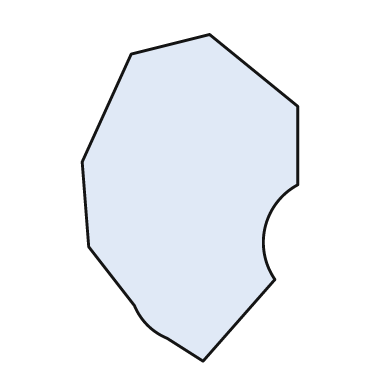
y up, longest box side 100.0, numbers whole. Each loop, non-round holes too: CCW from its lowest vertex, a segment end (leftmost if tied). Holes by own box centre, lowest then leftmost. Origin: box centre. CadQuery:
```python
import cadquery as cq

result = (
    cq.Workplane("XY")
    .moveTo(4.0, -50.0)
    .lineTo(26.0, -25.0)
    .threePointArc((23.0, -9.0), (33.0, 4.0))
    .lineTo(33.0, 28.0)
    .lineTo(6.0, 50.0)
    .lineTo(-18.0, 44.0)
    .lineTo(-33.0, 11.0)
    .lineTo(-31.0, -15.0)
    .lineTo(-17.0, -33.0)
    .threePointArc((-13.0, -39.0), (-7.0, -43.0))
    .close()
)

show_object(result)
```